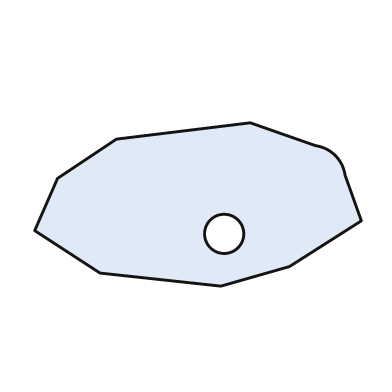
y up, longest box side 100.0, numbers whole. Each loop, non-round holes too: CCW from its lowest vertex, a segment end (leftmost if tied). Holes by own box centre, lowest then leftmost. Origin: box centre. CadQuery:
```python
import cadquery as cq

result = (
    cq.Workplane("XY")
    .moveTo(7.0, -25.0)
    .lineTo(28.0, -19.0)
    .lineTo(50.0, -5.0)
    .lineTo(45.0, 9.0)
    .threePointArc((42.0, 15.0), (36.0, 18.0))
    .lineTo(16.0, 25.0)
    .lineTo(-25.0, 20.0)
    .lineTo(-43.0, 8.0)
    .lineTo(-50.0, -8.0)
    .lineTo(-30.0, -21.0)
    .close()
    .moveTo(8.0, -9.0)
    .circle(6.0)
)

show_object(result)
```